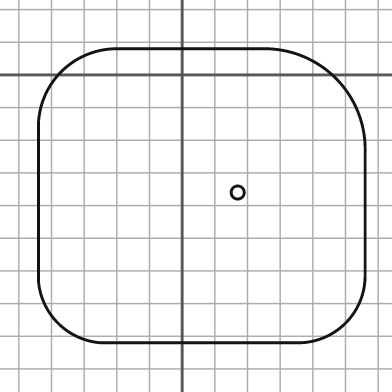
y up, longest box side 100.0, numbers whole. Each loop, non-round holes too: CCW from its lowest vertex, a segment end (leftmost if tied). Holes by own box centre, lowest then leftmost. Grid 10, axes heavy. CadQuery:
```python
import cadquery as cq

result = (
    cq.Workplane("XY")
    .moveTo(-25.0, -82.0)
    .lineTo(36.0, -82.0)
    .threePointArc((50.0, -76.0), (56.0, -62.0))
    .lineTo(56.0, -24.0)
    .threePointArc((47.0, -1.0), (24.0, 8.0))
    .lineTo(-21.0, 8.0)
    .threePointArc((-37.0, 1.0), (-44.0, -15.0))
    .lineTo(-44.0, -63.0)
    .threePointArc((-38.0, -76.0), (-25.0, -82.0))
    .close()
    .moveTo(17.0, -36.0)
    .circle(2.0)
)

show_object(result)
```